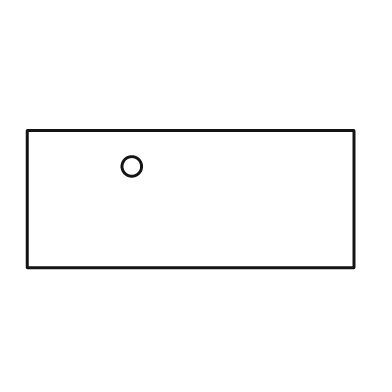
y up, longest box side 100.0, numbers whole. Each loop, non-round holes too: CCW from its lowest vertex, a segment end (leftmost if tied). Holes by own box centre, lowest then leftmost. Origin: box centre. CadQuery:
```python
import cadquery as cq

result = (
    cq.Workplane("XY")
    .moveTo(-50.0, -21.0)
    .lineTo(50.0, -21.0)
    .lineTo(50.0, 21.0)
    .lineTo(-50.0, 21.0)
    .close()
    .moveTo(-18.0, 10.0)
    .circle(3.0)
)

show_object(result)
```